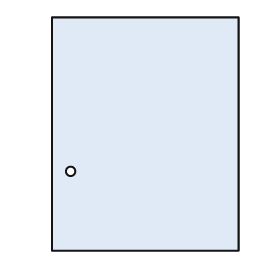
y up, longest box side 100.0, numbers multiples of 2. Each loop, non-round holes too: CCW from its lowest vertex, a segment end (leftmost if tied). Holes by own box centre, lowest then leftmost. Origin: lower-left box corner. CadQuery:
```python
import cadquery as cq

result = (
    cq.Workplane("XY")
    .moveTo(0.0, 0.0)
    .lineTo(80.0, 0.0)
    .lineTo(80.0, 100.0)
    .lineTo(0.0, 100.0)
    .close()
    .moveTo(8.0, 34.0)
    .circle(2.0)
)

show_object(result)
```